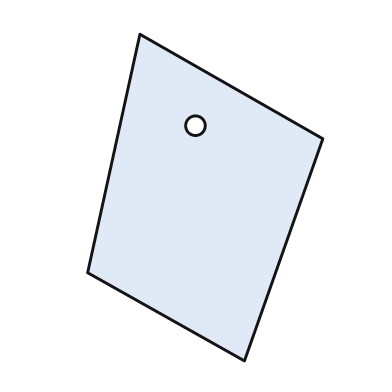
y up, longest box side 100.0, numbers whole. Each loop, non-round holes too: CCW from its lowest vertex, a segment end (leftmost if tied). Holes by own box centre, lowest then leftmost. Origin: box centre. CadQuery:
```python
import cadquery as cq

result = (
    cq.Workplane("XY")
    .moveTo(12.0, -50.0)
    .lineTo(36.0, 18.0)
    .lineTo(-20.0, 50.0)
    .lineTo(-36.0, -23.0)
    .close()
    .moveTo(-3.0, 22.0)
    .circle(3.0)
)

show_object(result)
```